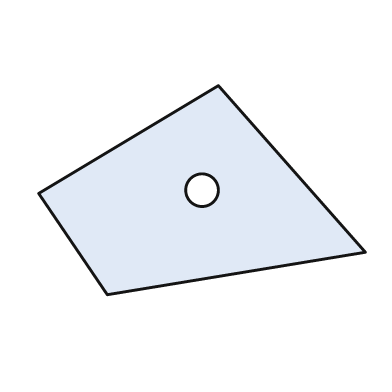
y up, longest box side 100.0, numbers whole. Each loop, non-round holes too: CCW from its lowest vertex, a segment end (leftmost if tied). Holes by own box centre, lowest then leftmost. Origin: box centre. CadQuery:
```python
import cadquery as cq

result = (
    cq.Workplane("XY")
    .moveTo(-29.0, -32.0)
    .lineTo(50.0, -19.0)
    .lineTo(5.0, 32.0)
    .lineTo(-50.0, -1.0)
    .close()
    .moveTo(0.0, 0.0)
    .circle(5.0)
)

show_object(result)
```